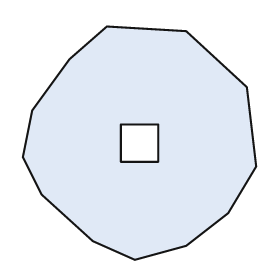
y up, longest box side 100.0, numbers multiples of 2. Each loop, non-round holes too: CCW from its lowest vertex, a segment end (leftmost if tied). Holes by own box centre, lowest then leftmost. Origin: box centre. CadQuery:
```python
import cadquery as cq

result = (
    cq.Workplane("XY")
    .moveTo(-2.0, -50.0)
    .lineTo(20.0, -44.0)
    .lineTo(38.0, -30.0)
    .lineTo(50.0, -10.0)
    .lineTo(46.0, 24.0)
    .lineTo(20.0, 48.0)
    .lineTo(-14.0, 50.0)
    .lineTo(-30.0, 36.0)
    .lineTo(-46.0, 14.0)
    .lineTo(-50.0, -6.0)
    .lineTo(-42.0, -22.0)
    .lineTo(-20.0, -42.0)
    .close()
    .moveTo(-8.0, -8.0)
    .lineTo(8.0, -8.0)
    .lineTo(8.0, 8.0)
    .lineTo(-8.0, 8.0)
    .close()
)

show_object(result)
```